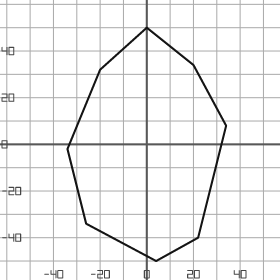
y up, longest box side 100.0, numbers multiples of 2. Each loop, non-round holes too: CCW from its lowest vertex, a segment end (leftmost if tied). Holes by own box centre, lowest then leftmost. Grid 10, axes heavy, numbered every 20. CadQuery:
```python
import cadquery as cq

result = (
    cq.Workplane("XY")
    .moveTo(4.0, -50.0)
    .lineTo(22.0, -40.0)
    .lineTo(34.0, 8.0)
    .lineTo(20.0, 34.0)
    .lineTo(0.0, 50.0)
    .lineTo(-20.0, 32.0)
    .lineTo(-34.0, -2.0)
    .lineTo(-26.0, -34.0)
    .close()
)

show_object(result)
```